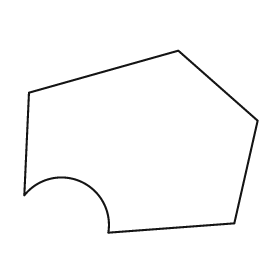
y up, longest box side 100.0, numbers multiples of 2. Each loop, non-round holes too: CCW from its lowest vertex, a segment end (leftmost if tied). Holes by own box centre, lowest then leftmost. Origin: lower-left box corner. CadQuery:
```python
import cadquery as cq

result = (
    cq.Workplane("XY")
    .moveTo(36.0, 0.0)
    .lineTo(90.0, 4.0)
    .lineTo(100.0, 48.0)
    .lineTo(66.0, 78.0)
    .lineTo(2.0, 60.0)
    .lineTo(0.0, 16.0)
    .threePointArc((24.0, 22.0), (36.0, 0.0))
    .close()
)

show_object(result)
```